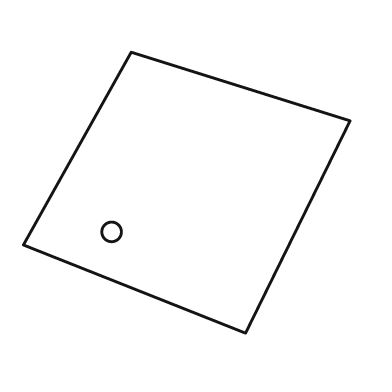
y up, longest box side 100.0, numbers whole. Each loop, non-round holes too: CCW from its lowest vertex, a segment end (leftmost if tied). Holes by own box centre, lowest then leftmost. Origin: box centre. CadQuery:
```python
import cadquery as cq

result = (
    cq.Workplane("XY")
    .moveTo(18.0, -43.0)
    .lineTo(50.0, 22.0)
    .lineTo(-17.0, 43.0)
    .lineTo(-50.0, -16.0)
    .close()
    .moveTo(-23.0, -12.0)
    .circle(3.0)
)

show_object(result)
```